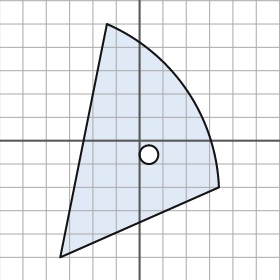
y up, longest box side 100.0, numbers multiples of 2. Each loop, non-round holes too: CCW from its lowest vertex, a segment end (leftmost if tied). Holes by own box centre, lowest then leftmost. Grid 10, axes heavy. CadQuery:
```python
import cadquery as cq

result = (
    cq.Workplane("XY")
    .moveTo(-34.0, -50.0)
    .lineTo(34.0, -20.0)
    .threePointArc((20.0, 22.0), (-14.0, 50.0))
    .close()
    .moveTo(4.0, -6.0)
    .circle(4.0)
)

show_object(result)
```